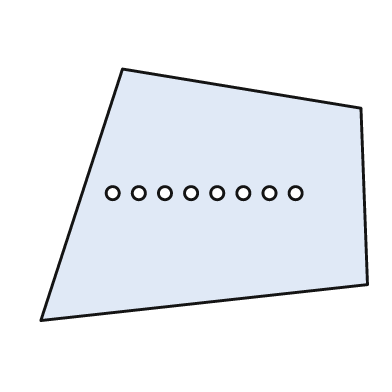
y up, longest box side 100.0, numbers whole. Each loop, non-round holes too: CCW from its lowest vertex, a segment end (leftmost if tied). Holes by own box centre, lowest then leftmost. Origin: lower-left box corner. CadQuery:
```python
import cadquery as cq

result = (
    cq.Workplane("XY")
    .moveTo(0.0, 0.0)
    .lineTo(100.0, 11.0)
    .lineTo(98.0, 65.0)
    .lineTo(25.0, 77.0)
    .close()
    .moveTo(22.0, 39.0)
    .circle(2.0)
    .moveTo(30.0, 39.0)
    .circle(2.0)
    .moveTo(38.0, 39.0)
    .circle(2.0)
    .moveTo(46.0, 39.0)
    .circle(2.0)
    .moveTo(54.0, 39.0)
    .circle(2.0)
    .moveTo(62.0, 39.0)
    .circle(2.0)
    .moveTo(70.0, 39.0)
    .circle(2.0)
    .moveTo(78.0, 39.0)
    .circle(2.0)
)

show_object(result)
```